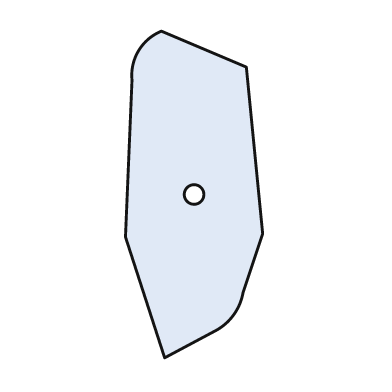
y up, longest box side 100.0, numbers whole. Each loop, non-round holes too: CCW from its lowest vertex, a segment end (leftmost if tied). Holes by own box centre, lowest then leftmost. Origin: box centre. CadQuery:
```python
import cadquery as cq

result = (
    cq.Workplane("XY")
    .moveTo(-9.0, -50.0)
    .lineTo(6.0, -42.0)
    .threePointArc((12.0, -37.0), (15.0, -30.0))
    .lineTo(21.0, -12.0)
    .lineTo(16.0, 39.0)
    .lineTo(-10.0, 50.0)
    .threePointArc((-17.0, 44.0), (-19.0, 35.0))
    .lineTo(-21.0, -13.0)
    .close()
    .moveTo(0.0, 0.0)
    .circle(3.0)
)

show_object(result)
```